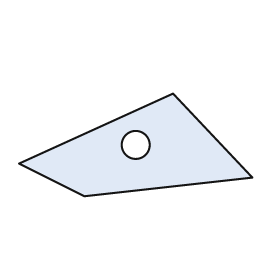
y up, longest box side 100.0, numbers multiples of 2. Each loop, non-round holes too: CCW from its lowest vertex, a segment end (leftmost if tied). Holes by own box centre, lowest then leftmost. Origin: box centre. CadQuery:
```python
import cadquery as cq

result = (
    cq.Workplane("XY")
    .moveTo(-22.0, -22.0)
    .lineTo(50.0, -14.0)
    .lineTo(16.0, 22.0)
    .lineTo(-50.0, -8.0)
    .close()
    .moveTo(0.0, 0.0)
    .circle(6.0)
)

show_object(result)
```